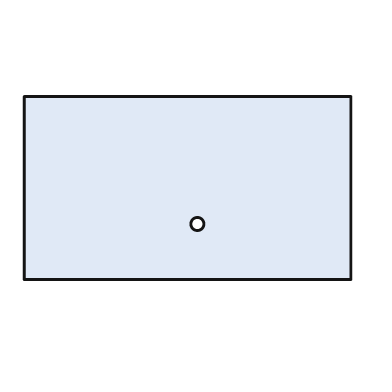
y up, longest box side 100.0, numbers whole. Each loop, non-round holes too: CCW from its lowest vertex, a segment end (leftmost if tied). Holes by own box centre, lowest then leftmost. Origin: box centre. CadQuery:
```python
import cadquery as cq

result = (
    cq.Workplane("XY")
    .moveTo(-50.0, -28.0)
    .lineTo(50.0, -28.0)
    .lineTo(50.0, 28.0)
    .lineTo(-50.0, 28.0)
    .close()
    .moveTo(3.0, -11.0)
    .circle(2.0)
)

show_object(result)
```